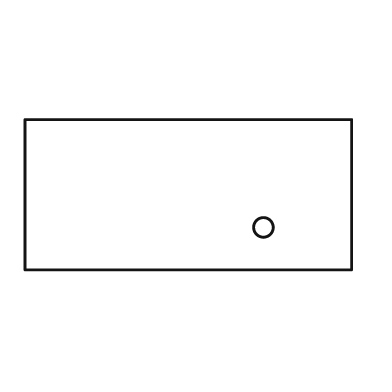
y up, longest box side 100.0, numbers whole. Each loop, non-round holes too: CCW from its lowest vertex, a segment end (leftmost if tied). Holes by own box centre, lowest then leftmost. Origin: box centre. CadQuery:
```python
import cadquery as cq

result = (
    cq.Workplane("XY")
    .moveTo(-50.0, -23.0)
    .lineTo(50.0, -23.0)
    .lineTo(50.0, 23.0)
    .lineTo(-50.0, 23.0)
    .close()
    .moveTo(23.0, -10.0)
    .circle(3.0)
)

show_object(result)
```